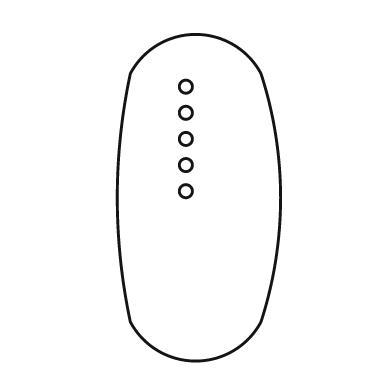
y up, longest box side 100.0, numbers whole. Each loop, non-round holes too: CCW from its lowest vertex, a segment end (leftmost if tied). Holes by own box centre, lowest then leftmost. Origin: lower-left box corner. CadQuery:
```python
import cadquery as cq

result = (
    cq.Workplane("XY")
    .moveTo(4.0, 12.0)
    .threePointArc((24.0, 0.0), (44.0, 12.0))
    .threePointArc((50.0, 50.0), (44.0, 88.0))
    .threePointArc((24.0, 100.0), (4.0, 88.0))
    .threePointArc((0.0, 50.0), (4.0, 12.0))
    .close()
    .moveTo(21.0, 52.0)
    .circle(2.0)
    .moveTo(21.0, 60.0)
    .circle(2.0)
    .moveTo(21.0, 68.0)
    .circle(2.0)
    .moveTo(21.0, 76.0)
    .circle(2.0)
    .moveTo(21.0, 84.0)
    .circle(2.0)
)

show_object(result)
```